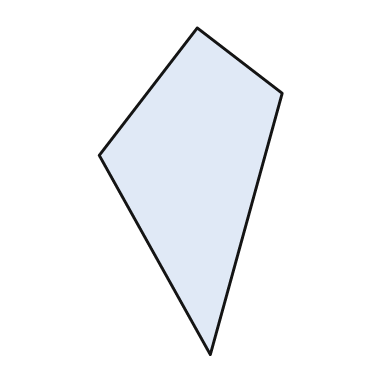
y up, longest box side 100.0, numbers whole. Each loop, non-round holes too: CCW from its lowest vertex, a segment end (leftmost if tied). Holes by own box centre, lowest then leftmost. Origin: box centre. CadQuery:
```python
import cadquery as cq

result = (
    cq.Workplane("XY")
    .moveTo(6.0, -50.0)
    .lineTo(28.0, 30.0)
    .lineTo(2.0, 50.0)
    .lineTo(-28.0, 11.0)
    .close()
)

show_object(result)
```